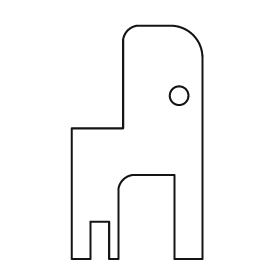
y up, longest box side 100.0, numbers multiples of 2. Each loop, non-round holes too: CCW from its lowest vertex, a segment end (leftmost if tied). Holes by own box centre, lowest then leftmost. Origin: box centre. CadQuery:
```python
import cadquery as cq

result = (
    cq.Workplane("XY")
    .moveTo(-28.0, -50.0)
    .lineTo(-20.0, -50.0)
    .lineTo(-20.0, -34.0)
    .lineTo(-12.0, -34.0)
    .lineTo(-12.0, -50.0)
    .lineTo(-8.0, -50.0)
    .lineTo(-8.0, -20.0)
    .threePointArc((-6.0, -16.0), (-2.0, -14.0))
    .lineTo(16.0, -14.0)
    .lineTo(16.0, -50.0)
    .lineTo(28.0, -50.0)
    .lineTo(28.0, 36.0)
    .threePointArc((24.0, 46.0), (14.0, 50.0))
    .lineTo(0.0, 50.0)
    .threePointArc((-4.0, 48.0), (-6.0, 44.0))
    .lineTo(-6.0, 6.0)
    .lineTo(-28.0, 6.0)
    .close()
    .moveTo(18.0, 20.0)
    .circle(4.0)
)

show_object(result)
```